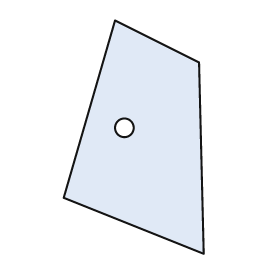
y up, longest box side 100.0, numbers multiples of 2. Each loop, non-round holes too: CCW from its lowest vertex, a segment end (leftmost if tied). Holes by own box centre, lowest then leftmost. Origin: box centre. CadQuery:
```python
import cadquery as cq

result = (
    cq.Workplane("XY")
    .moveTo(30.0, -50.0)
    .lineTo(28.0, 32.0)
    .lineTo(-8.0, 50.0)
    .lineTo(-30.0, -26.0)
    .close()
    .moveTo(-4.0, 4.0)
    .circle(4.0)
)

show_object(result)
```